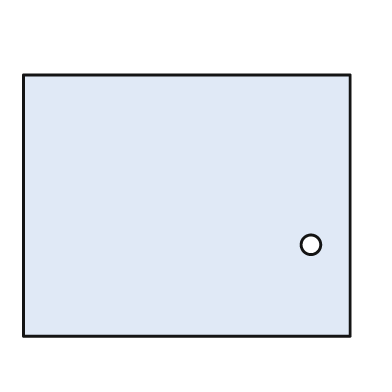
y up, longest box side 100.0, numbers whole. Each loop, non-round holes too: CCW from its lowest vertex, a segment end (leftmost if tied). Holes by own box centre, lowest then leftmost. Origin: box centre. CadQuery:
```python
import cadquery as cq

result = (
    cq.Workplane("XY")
    .moveTo(-50.0, -40.0)
    .lineTo(50.0, -40.0)
    .lineTo(50.0, 40.0)
    .lineTo(-50.0, 40.0)
    .close()
    .moveTo(38.0, -12.0)
    .circle(3.0)
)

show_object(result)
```